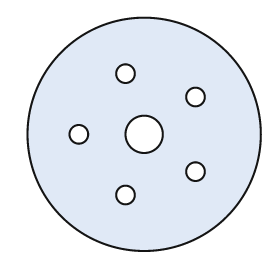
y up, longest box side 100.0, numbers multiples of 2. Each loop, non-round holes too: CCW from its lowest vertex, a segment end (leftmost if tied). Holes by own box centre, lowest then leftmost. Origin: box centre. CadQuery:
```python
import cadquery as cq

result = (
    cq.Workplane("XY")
    .moveTo(0.0, 0.0)
    .circle(50.0)
    .moveTo(-8.0, -26.0)
    .circle(4.0)
    .moveTo(22.0, -16.0)
    .circle(4.0)
    .moveTo(-28.0, 0.0)
    .circle(4.0)
    .moveTo(0.0, 0.0)
    .circle(8.0)
    .moveTo(22.0, 16.0)
    .circle(4.0)
    .moveTo(-8.0, 26.0)
    .circle(4.0)
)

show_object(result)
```